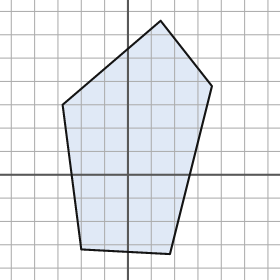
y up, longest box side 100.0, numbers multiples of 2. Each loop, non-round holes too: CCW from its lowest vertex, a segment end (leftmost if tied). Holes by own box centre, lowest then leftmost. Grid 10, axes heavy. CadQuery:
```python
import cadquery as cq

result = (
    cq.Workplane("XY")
    .moveTo(18.0, -34.0)
    .lineTo(36.0, 38.0)
    .lineTo(14.0, 66.0)
    .lineTo(-28.0, 30.0)
    .lineTo(-20.0, -32.0)
    .close()
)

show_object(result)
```